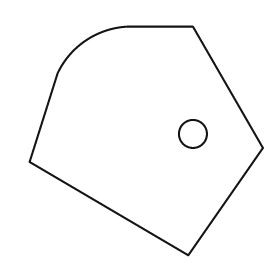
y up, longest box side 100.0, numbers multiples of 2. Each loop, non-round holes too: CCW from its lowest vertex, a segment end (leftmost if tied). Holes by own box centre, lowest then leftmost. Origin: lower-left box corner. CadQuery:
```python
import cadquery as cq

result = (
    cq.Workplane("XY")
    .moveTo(68.0, 0.0)
    .lineTo(100.0, 46.0)
    .lineTo(70.0, 98.0)
    .lineTo(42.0, 98.0)
    .threePointArc((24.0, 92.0), (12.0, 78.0))
    .lineTo(0.0, 40.0)
    .close()
    .moveTo(70.0, 52.0)
    .circle(6.0)
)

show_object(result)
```